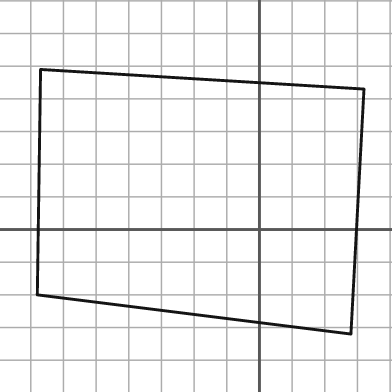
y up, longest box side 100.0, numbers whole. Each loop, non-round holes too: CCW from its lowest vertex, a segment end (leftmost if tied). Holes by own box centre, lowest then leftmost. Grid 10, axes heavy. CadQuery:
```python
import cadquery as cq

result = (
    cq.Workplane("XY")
    .moveTo(28.0, -32.0)
    .lineTo(32.0, 43.0)
    .lineTo(-67.0, 49.0)
    .lineTo(-68.0, -20.0)
    .close()
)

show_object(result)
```